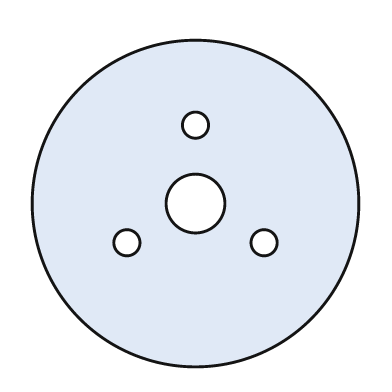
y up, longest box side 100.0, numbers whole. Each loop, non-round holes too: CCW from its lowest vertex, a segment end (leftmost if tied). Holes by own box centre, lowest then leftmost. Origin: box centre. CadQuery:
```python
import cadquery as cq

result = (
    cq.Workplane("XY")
    .moveTo(0.0, 0.0)
    .circle(50.0)
    .moveTo(-21.0, -12.0)
    .circle(4.0)
    .moveTo(21.0, -12.0)
    .circle(4.0)
    .moveTo(0.0, 0.0)
    .circle(9.0)
    .moveTo(0.0, 24.0)
    .circle(4.0)
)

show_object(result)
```